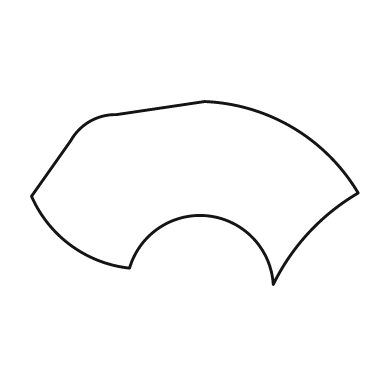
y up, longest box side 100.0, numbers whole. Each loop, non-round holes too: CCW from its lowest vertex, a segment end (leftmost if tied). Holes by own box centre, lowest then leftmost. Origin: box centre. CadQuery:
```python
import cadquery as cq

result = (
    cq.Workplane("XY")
    .moveTo(24.0, -28.0)
    .threePointArc((35.0, -12.0), (50.0, 0.0))
    .threePointArc((30.0, 20.0), (3.0, 28.0))
    .lineTo(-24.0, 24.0)
    .threePointArc((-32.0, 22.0), (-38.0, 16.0))
    .lineTo(-50.0, -1.0)
    .threePointArc((-38.0, -16.0), (-20.0, -23.0))
    .threePointArc((4.0, -7.0), (24.0, -28.0))
    .close()
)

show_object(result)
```